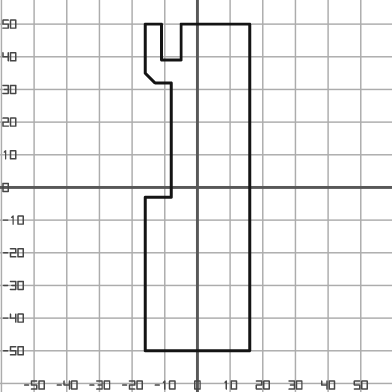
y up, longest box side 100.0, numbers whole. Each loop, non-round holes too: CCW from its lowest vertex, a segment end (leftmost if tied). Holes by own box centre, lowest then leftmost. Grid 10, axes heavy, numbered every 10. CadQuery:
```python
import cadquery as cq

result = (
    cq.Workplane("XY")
    .moveTo(-16.0, -50.0)
    .lineTo(16.0, -50.0)
    .lineTo(16.0, 50.0)
    .lineTo(-5.0, 50.0)
    .lineTo(-5.0, 39.0)
    .lineTo(-11.0, 39.0)
    .lineTo(-11.0, 50.0)
    .lineTo(-16.0, 50.0)
    .lineTo(-16.0, 35.0)
    .lineTo(-13.0, 32.0)
    .lineTo(-8.0, 32.0)
    .lineTo(-8.0, -3.0)
    .lineTo(-16.0, -3.0)
    .close()
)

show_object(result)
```